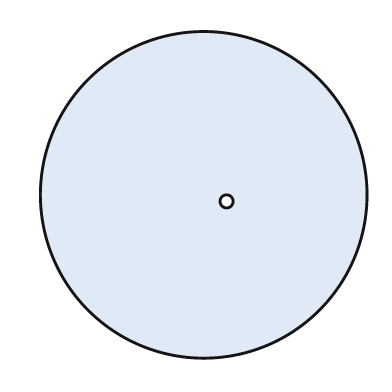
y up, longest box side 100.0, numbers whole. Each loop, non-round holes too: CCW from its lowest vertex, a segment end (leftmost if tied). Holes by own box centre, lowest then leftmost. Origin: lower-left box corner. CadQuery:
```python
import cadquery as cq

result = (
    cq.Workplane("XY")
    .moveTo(50.0, 50.0)
    .circle(50.0)
    .moveTo(57.0, 48.0)
    .circle(2.0)
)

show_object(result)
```